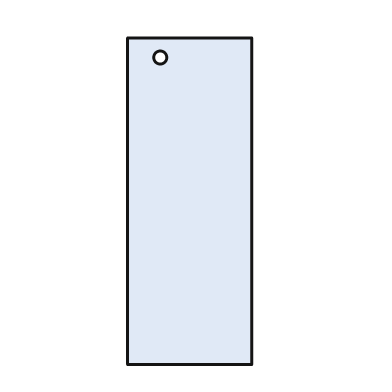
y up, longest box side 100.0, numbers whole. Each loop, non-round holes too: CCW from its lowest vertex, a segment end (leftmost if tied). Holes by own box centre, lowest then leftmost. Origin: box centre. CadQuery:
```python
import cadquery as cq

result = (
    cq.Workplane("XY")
    .moveTo(-19.0, -50.0)
    .lineTo(19.0, -50.0)
    .lineTo(19.0, 50.0)
    .lineTo(-19.0, 50.0)
    .close()
    .moveTo(-9.0, 44.0)
    .circle(2.0)
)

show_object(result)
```